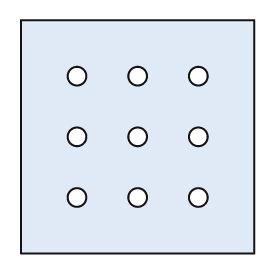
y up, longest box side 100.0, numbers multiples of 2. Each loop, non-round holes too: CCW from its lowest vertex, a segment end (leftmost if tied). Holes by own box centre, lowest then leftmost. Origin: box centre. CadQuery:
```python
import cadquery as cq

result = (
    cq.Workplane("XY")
    .moveTo(-50.0, -50.0)
    .lineTo(50.0, -50.0)
    .lineTo(50.0, 50.0)
    .lineTo(-50.0, 50.0)
    .close()
    .moveTo(-26.0, -26.0)
    .circle(4.0)
    .moveTo(0.0, -26.0)
    .circle(4.0)
    .moveTo(26.0, -26.0)
    .circle(4.0)
    .moveTo(-26.0, 0.0)
    .circle(4.0)
    .moveTo(0.0, 0.0)
    .circle(4.0)
    .moveTo(26.0, 0.0)
    .circle(4.0)
    .moveTo(-26.0, 26.0)
    .circle(4.0)
    .moveTo(0.0, 26.0)
    .circle(4.0)
    .moveTo(26.0, 26.0)
    .circle(4.0)
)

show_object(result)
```